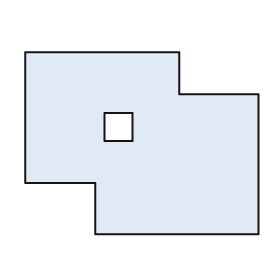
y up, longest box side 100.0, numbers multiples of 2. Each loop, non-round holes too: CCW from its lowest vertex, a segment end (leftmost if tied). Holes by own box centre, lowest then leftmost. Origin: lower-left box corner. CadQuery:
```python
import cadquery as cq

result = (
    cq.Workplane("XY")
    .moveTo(30.0, 0.0)
    .lineTo(100.0, 0.0)
    .lineTo(100.0, 60.0)
    .lineTo(66.0, 60.0)
    .lineTo(66.0, 78.0)
    .lineTo(0.0, 78.0)
    .lineTo(0.0, 22.0)
    .lineTo(30.0, 22.0)
    .close()
    .moveTo(34.0, 40.0)
    .lineTo(46.0, 40.0)
    .lineTo(46.0, 52.0)
    .lineTo(34.0, 52.0)
    .close()
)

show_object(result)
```